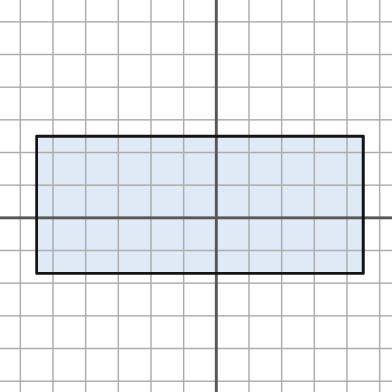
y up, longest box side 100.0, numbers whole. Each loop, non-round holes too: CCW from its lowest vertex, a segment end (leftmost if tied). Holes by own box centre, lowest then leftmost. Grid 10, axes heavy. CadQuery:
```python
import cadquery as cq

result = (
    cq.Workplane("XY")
    .moveTo(-55.0, -17.0)
    .lineTo(45.0, -17.0)
    .lineTo(45.0, 25.0)
    .lineTo(-55.0, 25.0)
    .close()
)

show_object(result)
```